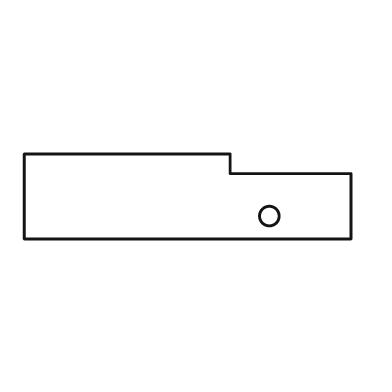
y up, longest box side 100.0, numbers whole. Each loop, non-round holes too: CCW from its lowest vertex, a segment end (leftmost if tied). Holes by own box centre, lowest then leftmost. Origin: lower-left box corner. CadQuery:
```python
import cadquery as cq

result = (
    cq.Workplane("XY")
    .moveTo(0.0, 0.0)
    .lineTo(100.0, 0.0)
    .lineTo(100.0, 20.0)
    .lineTo(63.0, 20.0)
    .lineTo(63.0, 26.0)
    .lineTo(0.0, 26.0)
    .close()
    .moveTo(75.0, 7.0)
    .circle(3.0)
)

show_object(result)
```